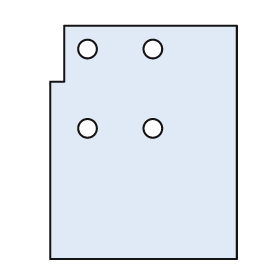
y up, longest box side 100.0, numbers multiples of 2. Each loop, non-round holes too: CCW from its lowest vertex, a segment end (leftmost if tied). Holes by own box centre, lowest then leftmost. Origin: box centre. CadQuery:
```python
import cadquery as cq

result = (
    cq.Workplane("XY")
    .moveTo(-40.0, -50.0)
    .lineTo(40.0, -50.0)
    .lineTo(40.0, 50.0)
    .lineTo(-34.0, 50.0)
    .lineTo(-34.0, 26.0)
    .lineTo(-40.0, 26.0)
    .close()
    .moveTo(-24.0, 6.0)
    .circle(4.0)
    .moveTo(4.0, 6.0)
    .circle(4.0)
    .moveTo(-24.0, 40.0)
    .circle(4.0)
    .moveTo(4.0, 40.0)
    .circle(4.0)
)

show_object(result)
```